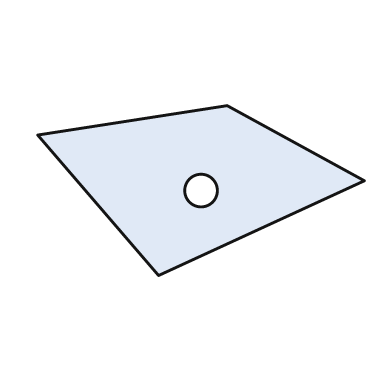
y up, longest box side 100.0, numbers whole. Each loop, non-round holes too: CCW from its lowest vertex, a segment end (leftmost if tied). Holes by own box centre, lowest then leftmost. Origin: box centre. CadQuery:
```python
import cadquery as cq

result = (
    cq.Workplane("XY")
    .moveTo(-13.0, -26.0)
    .lineTo(50.0, 3.0)
    .lineTo(8.0, 26.0)
    .lineTo(-50.0, 17.0)
    .close()
    .moveTo(0.0, 0.0)
    .circle(5.0)
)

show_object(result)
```